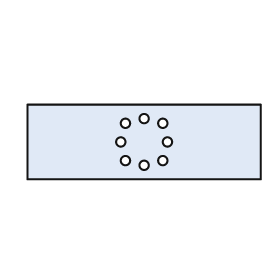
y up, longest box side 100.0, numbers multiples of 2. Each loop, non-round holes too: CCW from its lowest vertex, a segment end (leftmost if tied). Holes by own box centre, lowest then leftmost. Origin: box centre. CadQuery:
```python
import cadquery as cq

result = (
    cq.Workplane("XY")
    .moveTo(-50.0, -16.0)
    .lineTo(50.0, -16.0)
    .lineTo(50.0, 16.0)
    .lineTo(-50.0, 16.0)
    .close()
    .moveTo(0.0, -10.0)
    .circle(2.0)
    .moveTo(-8.0, -8.0)
    .circle(2.0)
    .moveTo(8.0, -8.0)
    .circle(2.0)
    .moveTo(-10.0, 0.0)
    .circle(2.0)
    .moveTo(10.0, 0.0)
    .circle(2.0)
    .moveTo(-8.0, 8.0)
    .circle(2.0)
    .moveTo(8.0, 8.0)
    .circle(2.0)
    .moveTo(0.0, 10.0)
    .circle(2.0)
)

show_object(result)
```